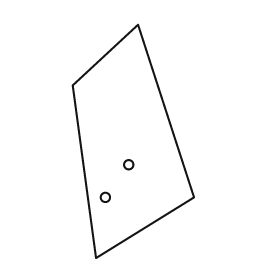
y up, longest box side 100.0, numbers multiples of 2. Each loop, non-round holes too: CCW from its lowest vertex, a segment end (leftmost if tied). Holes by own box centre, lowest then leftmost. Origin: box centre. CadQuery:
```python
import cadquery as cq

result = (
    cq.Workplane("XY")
    .moveTo(-16.0, -50.0)
    .lineTo(26.0, -24.0)
    .lineTo(2.0, 50.0)
    .lineTo(-26.0, 24.0)
    .close()
    .moveTo(-12.0, -24.0)
    .circle(2.0)
    .moveTo(-2.0, -10.0)
    .circle(2.0)
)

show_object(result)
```